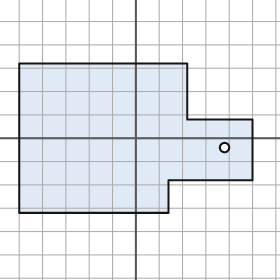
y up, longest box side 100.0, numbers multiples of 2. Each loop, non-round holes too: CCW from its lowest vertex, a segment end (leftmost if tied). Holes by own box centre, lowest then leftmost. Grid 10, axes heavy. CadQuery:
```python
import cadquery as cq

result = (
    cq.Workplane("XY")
    .moveTo(-50.0, -32.0)
    .lineTo(14.0, -32.0)
    .lineTo(14.0, -18.0)
    .lineTo(50.0, -18.0)
    .lineTo(50.0, 8.0)
    .lineTo(22.0, 8.0)
    .lineTo(22.0, 32.0)
    .lineTo(-50.0, 32.0)
    .close()
    .moveTo(38.0, -4.0)
    .circle(2.0)
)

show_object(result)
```